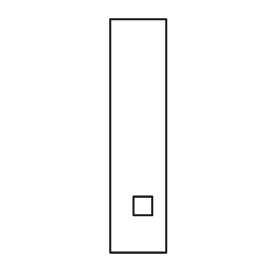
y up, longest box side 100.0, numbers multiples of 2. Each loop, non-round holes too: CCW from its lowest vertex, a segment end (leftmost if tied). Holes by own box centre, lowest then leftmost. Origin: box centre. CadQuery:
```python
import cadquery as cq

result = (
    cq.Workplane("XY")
    .moveTo(-12.0, -50.0)
    .lineTo(12.0, -50.0)
    .lineTo(12.0, 50.0)
    .lineTo(-12.0, 50.0)
    .close()
    .moveTo(-2.0, -34.0)
    .lineTo(6.0, -34.0)
    .lineTo(6.0, -26.0)
    .lineTo(-2.0, -26.0)
    .close()
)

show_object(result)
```